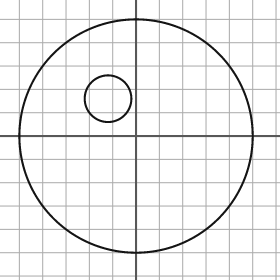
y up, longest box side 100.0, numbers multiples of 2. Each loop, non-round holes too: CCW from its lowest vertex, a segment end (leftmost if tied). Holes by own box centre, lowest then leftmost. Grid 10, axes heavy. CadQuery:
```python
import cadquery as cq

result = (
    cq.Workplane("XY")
    .moveTo(0.0, 0.0)
    .circle(50.0)
    .moveTo(-12.0, 16.0)
    .circle(10.0)
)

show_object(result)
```